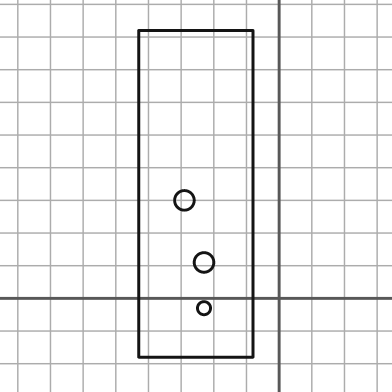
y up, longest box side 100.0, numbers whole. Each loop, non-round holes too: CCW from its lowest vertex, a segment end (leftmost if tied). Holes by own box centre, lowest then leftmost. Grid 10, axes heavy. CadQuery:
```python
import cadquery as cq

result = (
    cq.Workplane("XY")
    .moveTo(-43.0, -18.0)
    .lineTo(-8.0, -18.0)
    .lineTo(-8.0, 82.0)
    .lineTo(-43.0, 82.0)
    .close()
    .moveTo(-23.0, -3.0)
    .circle(2.0)
    .moveTo(-23.0, 11.0)
    .circle(3.0)
    .moveTo(-29.0, 30.0)
    .circle(3.0)
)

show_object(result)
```